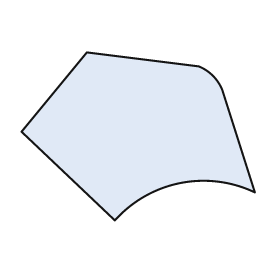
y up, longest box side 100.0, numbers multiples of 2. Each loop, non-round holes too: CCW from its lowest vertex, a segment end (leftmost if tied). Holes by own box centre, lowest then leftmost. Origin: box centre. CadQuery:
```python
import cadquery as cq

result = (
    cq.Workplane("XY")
    .moveTo(-10.0, -36.0)
    .threePointArc((18.0, -20.0), (50.0, -24.0))
    .lineTo(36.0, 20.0)
    .threePointArc((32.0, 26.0), (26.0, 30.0))
    .lineTo(-22.0, 36.0)
    .lineTo(-50.0, 2.0)
    .close()
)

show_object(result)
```